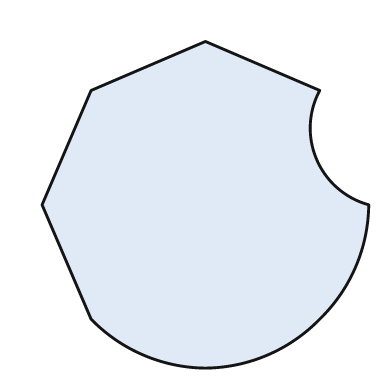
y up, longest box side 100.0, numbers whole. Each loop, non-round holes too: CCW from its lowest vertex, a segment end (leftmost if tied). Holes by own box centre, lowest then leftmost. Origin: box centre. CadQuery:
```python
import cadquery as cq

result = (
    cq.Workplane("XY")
    .moveTo(0.0, -50.0)
    .threePointArc((19.0, -46.0), (35.0, -35.0))
    .threePointArc((46.0, -19.0), (50.0, 0.0))
    .threePointArc((34.0, 14.0), (35.0, 35.0))
    .lineTo(0.0, 50.0)
    .lineTo(-35.0, 35.0)
    .lineTo(-50.0, 0.0)
    .lineTo(-35.0, -35.0)
    .threePointArc((-19.0, -46.0), (0.0, -50.0))
    .close()
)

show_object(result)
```